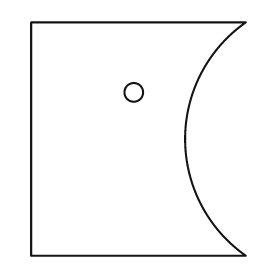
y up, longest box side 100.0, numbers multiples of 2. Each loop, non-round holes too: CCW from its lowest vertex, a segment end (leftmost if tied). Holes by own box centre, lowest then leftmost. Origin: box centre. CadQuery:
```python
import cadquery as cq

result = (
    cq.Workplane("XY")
    .moveTo(-46.0, -50.0)
    .lineTo(46.0, -50.0)
    .threePointArc((20.0, 0.0), (46.0, 50.0))
    .lineTo(-46.0, 50.0)
    .close()
    .moveTo(-2.0, 20.0)
    .circle(4.0)
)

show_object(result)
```